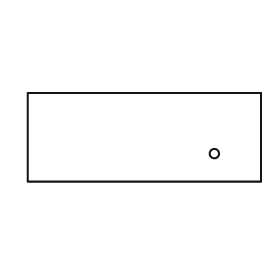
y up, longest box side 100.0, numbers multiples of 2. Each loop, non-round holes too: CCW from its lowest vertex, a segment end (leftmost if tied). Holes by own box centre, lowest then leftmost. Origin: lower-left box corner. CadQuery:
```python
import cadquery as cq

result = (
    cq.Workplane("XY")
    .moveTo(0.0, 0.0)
    .lineTo(100.0, 0.0)
    .lineTo(100.0, 38.0)
    .lineTo(0.0, 38.0)
    .close()
    .moveTo(80.0, 12.0)
    .circle(2.0)
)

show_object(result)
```